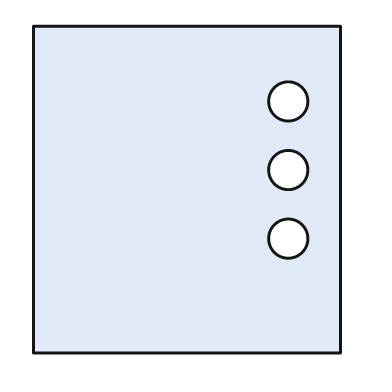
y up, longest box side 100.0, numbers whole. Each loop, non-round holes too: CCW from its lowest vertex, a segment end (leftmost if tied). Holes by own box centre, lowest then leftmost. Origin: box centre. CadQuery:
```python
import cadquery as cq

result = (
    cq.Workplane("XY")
    .moveTo(-47.0, -50.0)
    .lineTo(47.0, -50.0)
    .lineTo(47.0, 50.0)
    .lineTo(-47.0, 50.0)
    .close()
    .moveTo(31.0, -15.0)
    .circle(6.0)
    .moveTo(31.0, 6.0)
    .circle(6.0)
    .moveTo(31.0, 27.0)
    .circle(6.0)
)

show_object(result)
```